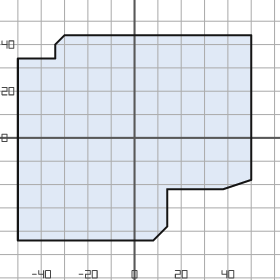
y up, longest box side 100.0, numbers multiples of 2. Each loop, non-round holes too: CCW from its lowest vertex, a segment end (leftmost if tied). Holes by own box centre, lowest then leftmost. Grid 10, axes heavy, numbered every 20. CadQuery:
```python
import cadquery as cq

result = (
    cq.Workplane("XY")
    .moveTo(-50.0, -44.0)
    .lineTo(8.0, -44.0)
    .lineTo(14.0, -38.0)
    .lineTo(14.0, -22.0)
    .lineTo(38.0, -22.0)
    .lineTo(50.0, -18.0)
    .lineTo(50.0, 44.0)
    .lineTo(-30.0, 44.0)
    .lineTo(-34.0, 40.0)
    .lineTo(-34.0, 34.0)
    .lineTo(-50.0, 34.0)
    .close()
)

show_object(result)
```